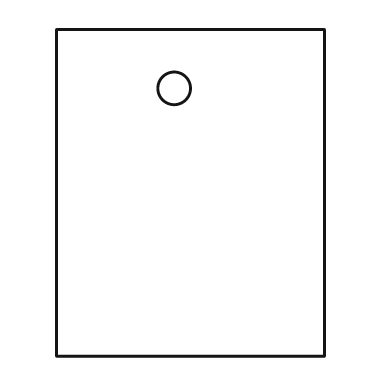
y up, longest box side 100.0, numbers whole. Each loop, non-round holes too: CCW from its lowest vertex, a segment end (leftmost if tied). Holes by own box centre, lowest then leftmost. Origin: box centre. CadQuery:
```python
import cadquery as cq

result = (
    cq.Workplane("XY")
    .moveTo(-41.0, -50.0)
    .lineTo(41.0, -50.0)
    .lineTo(41.0, 50.0)
    .lineTo(-41.0, 50.0)
    .close()
    .moveTo(-5.0, 32.0)
    .circle(5.0)
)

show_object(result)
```